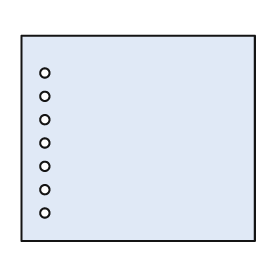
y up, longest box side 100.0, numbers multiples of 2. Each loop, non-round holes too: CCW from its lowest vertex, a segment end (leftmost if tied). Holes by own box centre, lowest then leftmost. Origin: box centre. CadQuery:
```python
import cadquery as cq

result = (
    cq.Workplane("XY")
    .moveTo(-50.0, -44.0)
    .lineTo(50.0, -44.0)
    .lineTo(50.0, 44.0)
    .lineTo(-50.0, 44.0)
    .close()
    .moveTo(-40.0, -32.0)
    .circle(2.0)
    .moveTo(-40.0, -22.0)
    .circle(2.0)
    .moveTo(-40.0, -12.0)
    .circle(2.0)
    .moveTo(-40.0, -2.0)
    .circle(2.0)
    .moveTo(-40.0, 8.0)
    .circle(2.0)
    .moveTo(-40.0, 18.0)
    .circle(2.0)
    .moveTo(-40.0, 28.0)
    .circle(2.0)
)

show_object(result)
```